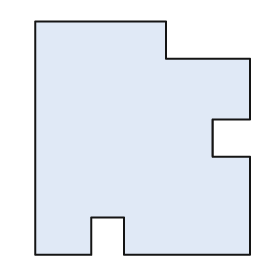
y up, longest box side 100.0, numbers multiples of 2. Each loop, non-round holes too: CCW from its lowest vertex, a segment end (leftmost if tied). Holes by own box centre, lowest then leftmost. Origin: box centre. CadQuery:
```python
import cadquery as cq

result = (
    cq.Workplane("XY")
    .moveTo(-46.0, -50.0)
    .lineTo(-22.0, -50.0)
    .lineTo(-22.0, -34.0)
    .lineTo(-8.0, -34.0)
    .lineTo(-8.0, -50.0)
    .lineTo(46.0, -50.0)
    .lineTo(46.0, -8.0)
    .lineTo(30.0, -8.0)
    .lineTo(30.0, 8.0)
    .lineTo(46.0, 8.0)
    .lineTo(46.0, 34.0)
    .lineTo(10.0, 34.0)
    .lineTo(10.0, 50.0)
    .lineTo(-46.0, 50.0)
    .close()
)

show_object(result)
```